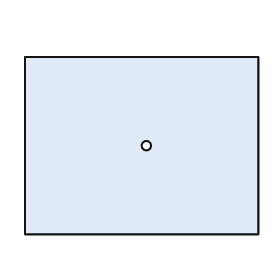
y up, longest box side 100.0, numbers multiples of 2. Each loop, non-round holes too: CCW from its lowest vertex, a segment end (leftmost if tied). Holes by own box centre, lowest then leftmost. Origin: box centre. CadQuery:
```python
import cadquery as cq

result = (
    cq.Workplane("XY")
    .moveTo(-50.0, -38.0)
    .lineTo(50.0, -38.0)
    .lineTo(50.0, 38.0)
    .lineTo(-50.0, 38.0)
    .close()
    .moveTo(2.0, 0.0)
    .circle(2.0)
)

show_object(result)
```